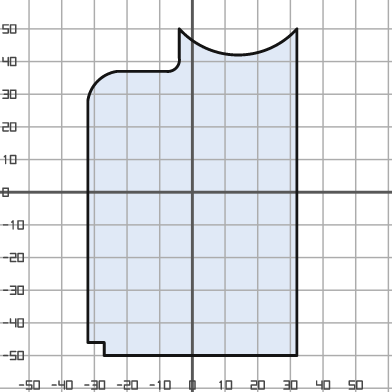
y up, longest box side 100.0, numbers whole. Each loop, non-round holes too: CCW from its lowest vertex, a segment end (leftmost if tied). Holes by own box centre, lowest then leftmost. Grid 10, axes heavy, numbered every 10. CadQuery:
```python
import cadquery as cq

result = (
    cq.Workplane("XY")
    .moveTo(-27.0, -50.0)
    .lineTo(32.0, -50.0)
    .lineTo(32.0, 50.0)
    .threePointArc((14.0, 42.0), (-4.0, 50.0))
    .lineTo(-4.0, 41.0)
    .threePointArc((-5.0, 38.0), (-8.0, 37.0))
    .lineTo(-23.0, 37.0)
    .threePointArc((-29.0, 34.0), (-32.0, 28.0))
    .lineTo(-32.0, -46.0)
    .lineTo(-27.0, -46.0)
    .close()
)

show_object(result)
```